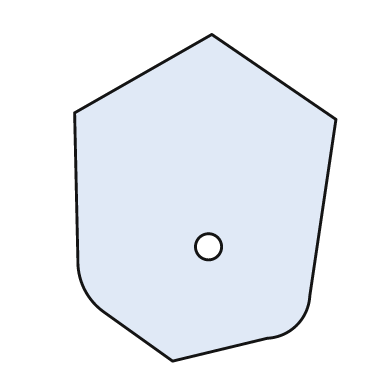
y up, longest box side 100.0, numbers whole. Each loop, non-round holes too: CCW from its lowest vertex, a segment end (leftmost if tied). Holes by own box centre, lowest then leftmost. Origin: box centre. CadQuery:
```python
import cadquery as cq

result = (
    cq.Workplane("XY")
    .moveTo(-10.0, -50.0)
    .lineTo(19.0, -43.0)
    .threePointArc((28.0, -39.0), (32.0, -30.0))
    .lineTo(40.0, 24.0)
    .lineTo(2.0, 50.0)
    .lineTo(-40.0, 26.0)
    .lineTo(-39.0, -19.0)
    .threePointArc((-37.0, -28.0), (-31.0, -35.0))
    .close()
    .moveTo(1.0, -15.0)
    .circle(4.0)
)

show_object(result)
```